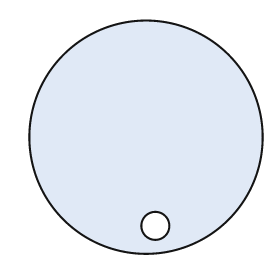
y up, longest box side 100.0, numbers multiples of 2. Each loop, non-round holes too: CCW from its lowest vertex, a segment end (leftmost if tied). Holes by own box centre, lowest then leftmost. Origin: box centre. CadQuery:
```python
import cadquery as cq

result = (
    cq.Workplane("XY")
    .moveTo(0.0, 0.0)
    .circle(50.0)
    .moveTo(4.0, -38.0)
    .circle(6.0)
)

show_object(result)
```